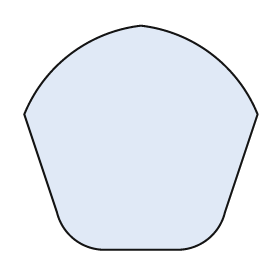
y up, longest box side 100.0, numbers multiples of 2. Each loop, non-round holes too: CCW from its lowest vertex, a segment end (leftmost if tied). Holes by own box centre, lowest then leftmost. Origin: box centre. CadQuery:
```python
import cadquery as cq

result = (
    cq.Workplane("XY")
    .moveTo(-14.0, -48.0)
    .lineTo(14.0, -48.0)
    .threePointArc((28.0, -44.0), (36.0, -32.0))
    .lineTo(50.0, 10.0)
    .threePointArc((30.0, 36.0), (0.0, 48.0))
    .threePointArc((-30.0, 36.0), (-50.0, 10.0))
    .lineTo(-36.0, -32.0)
    .threePointArc((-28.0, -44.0), (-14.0, -48.0))
    .close()
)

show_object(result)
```